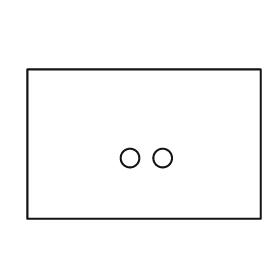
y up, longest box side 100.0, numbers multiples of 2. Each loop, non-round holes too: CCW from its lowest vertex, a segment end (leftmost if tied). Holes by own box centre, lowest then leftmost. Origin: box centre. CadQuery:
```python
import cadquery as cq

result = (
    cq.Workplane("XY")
    .moveTo(-50.0, -32.0)
    .lineTo(50.0, -32.0)
    .lineTo(50.0, 32.0)
    .lineTo(-50.0, 32.0)
    .close()
    .moveTo(-6.0, -6.0)
    .circle(4.0)
    .moveTo(8.0, -6.0)
    .circle(4.0)
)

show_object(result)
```